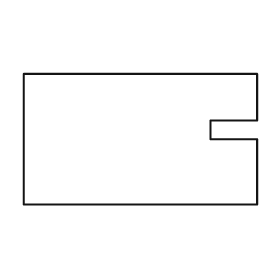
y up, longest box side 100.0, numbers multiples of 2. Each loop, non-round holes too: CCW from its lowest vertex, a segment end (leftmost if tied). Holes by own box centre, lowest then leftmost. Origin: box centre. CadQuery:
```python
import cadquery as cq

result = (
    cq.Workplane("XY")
    .moveTo(-50.0, -28.0)
    .lineTo(50.0, -28.0)
    .lineTo(50.0, 0.0)
    .lineTo(30.0, 0.0)
    .lineTo(30.0, 8.0)
    .lineTo(50.0, 8.0)
    .lineTo(50.0, 28.0)
    .lineTo(-50.0, 28.0)
    .close()
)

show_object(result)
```